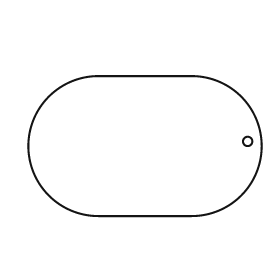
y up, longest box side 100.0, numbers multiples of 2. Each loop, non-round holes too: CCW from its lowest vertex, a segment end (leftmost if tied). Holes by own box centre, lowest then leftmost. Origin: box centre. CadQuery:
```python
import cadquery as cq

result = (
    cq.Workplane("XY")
    .moveTo(-20.0, -30.0)
    .lineTo(20.0, -30.0)
    .threePointArc((50.0, 0.0), (20.0, 30.0))
    .lineTo(-20.0, 30.0)
    .threePointArc((-50.0, 0.0), (-20.0, -30.0))
    .close()
    .moveTo(44.0, 2.0)
    .circle(2.0)
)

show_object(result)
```